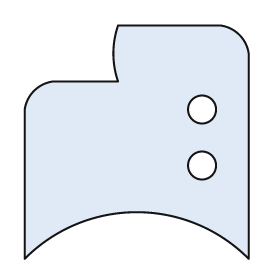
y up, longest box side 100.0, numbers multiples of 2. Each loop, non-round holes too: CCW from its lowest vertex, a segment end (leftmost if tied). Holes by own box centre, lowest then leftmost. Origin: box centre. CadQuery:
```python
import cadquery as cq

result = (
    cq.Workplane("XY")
    .moveTo(-48.0, -50.0)
    .threePointArc((0.0, -30.0), (48.0, -50.0))
    .lineTo(48.0, 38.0)
    .threePointArc((44.0, 46.0), (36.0, 50.0))
    .lineTo(-8.0, 50.0)
    .threePointArc((-10.0, 38.0), (-8.0, 26.0))
    .lineTo(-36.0, 26.0)
    .threePointArc((-44.0, 22.0), (-48.0, 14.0))
    .close()
    .moveTo(28.0, -10.0)
    .circle(6.0)
    .moveTo(28.0, 14.0)
    .circle(6.0)
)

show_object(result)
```